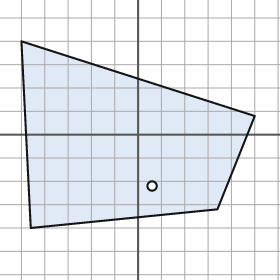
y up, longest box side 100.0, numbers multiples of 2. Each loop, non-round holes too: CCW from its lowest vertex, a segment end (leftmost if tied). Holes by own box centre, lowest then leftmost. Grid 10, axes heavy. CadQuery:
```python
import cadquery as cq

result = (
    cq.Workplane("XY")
    .moveTo(-46.0, -40.0)
    .lineTo(34.0, -32.0)
    .lineTo(50.0, 8.0)
    .lineTo(-50.0, 40.0)
    .close()
    .moveTo(6.0, -22.0)
    .circle(2.0)
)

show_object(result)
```